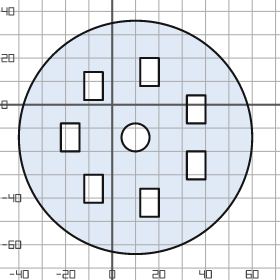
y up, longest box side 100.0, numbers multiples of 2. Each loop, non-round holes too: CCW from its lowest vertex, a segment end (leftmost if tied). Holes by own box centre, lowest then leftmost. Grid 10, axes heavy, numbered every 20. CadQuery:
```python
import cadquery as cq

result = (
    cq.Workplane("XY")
    .moveTo(10.0, -14.0)
    .circle(50.0)
    .moveTo(12.0, -48.0)
    .lineTo(20.0, -48.0)
    .lineTo(20.0, -36.0)
    .lineTo(12.0, -36.0)
    .close()
    .moveTo(-12.0, -42.0)
    .lineTo(-4.0, -42.0)
    .lineTo(-4.0, -30.0)
    .lineTo(-12.0, -30.0)
    .close()
    .moveTo(32.0, -32.0)
    .lineTo(40.0, -32.0)
    .lineTo(40.0, -20.0)
    .lineTo(32.0, -20.0)
    .close()
    .moveTo(-22.0, -20.0)
    .lineTo(-14.0, -20.0)
    .lineTo(-14.0, -8.0)
    .lineTo(-22.0, -8.0)
    .close()
    .moveTo(10.0, -14.0)
    .circle(6.0)
    .moveTo(32.0, -8.0)
    .lineTo(40.0, -8.0)
    .lineTo(40.0, 4.0)
    .lineTo(32.0, 4.0)
    .close()
    .moveTo(-12.0, 2.0)
    .lineTo(-4.0, 2.0)
    .lineTo(-4.0, 14.0)
    .lineTo(-12.0, 14.0)
    .close()
    .moveTo(12.0, 8.0)
    .lineTo(20.0, 8.0)
    .lineTo(20.0, 20.0)
    .lineTo(12.0, 20.0)
    .close()
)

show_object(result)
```